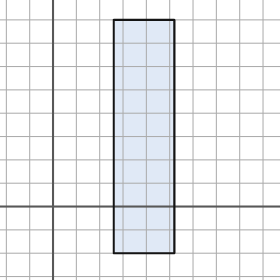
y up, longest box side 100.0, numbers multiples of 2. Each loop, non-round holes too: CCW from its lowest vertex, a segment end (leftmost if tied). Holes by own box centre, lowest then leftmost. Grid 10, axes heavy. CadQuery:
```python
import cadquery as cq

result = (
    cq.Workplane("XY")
    .moveTo(26.0, -20.0)
    .lineTo(52.0, -20.0)
    .lineTo(52.0, 80.0)
    .lineTo(26.0, 80.0)
    .close()
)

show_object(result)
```